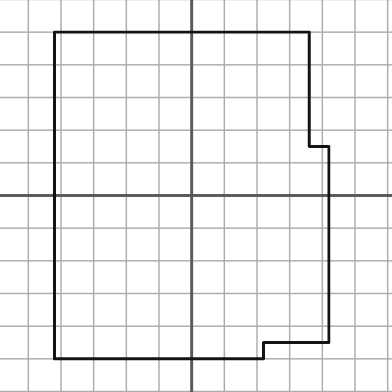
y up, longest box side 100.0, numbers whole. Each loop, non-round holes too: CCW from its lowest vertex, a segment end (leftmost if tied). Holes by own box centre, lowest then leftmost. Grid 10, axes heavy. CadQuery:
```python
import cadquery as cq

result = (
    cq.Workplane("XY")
    .moveTo(-42.0, -50.0)
    .lineTo(22.0, -50.0)
    .lineTo(22.0, -45.0)
    .lineTo(42.0, -45.0)
    .lineTo(42.0, 15.0)
    .lineTo(36.0, 15.0)
    .lineTo(36.0, 50.0)
    .lineTo(-42.0, 50.0)
    .close()
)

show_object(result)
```